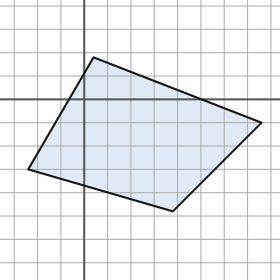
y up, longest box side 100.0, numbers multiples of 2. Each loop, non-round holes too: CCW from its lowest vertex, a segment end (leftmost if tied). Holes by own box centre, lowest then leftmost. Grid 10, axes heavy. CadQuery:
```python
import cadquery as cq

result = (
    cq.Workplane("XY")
    .moveTo(38.0, -48.0)
    .lineTo(76.0, -10.0)
    .lineTo(4.0, 18.0)
    .lineTo(-24.0, -30.0)
    .close()
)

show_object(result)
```